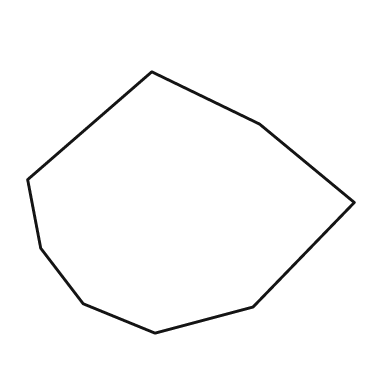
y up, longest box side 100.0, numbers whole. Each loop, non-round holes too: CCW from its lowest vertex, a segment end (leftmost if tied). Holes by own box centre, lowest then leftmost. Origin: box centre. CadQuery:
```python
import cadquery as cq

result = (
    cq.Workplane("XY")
    .moveTo(-11.0, -40.0)
    .lineTo(19.0, -32.0)
    .lineTo(50.0, 0.0)
    .lineTo(21.0, 24.0)
    .lineTo(-12.0, 40.0)
    .lineTo(-50.0, 7.0)
    .lineTo(-46.0, -14.0)
    .lineTo(-33.0, -31.0)
    .close()
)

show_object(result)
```